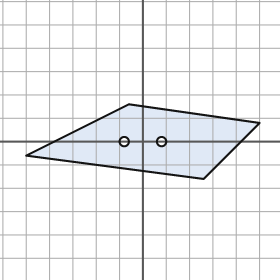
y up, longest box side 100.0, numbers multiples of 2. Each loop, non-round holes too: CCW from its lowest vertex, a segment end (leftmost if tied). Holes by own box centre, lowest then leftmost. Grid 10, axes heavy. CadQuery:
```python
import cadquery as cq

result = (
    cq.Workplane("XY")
    .moveTo(26.0, -16.0)
    .lineTo(50.0, 8.0)
    .lineTo(-6.0, 16.0)
    .lineTo(-50.0, -6.0)
    .close()
    .moveTo(-8.0, 0.0)
    .circle(2.0)
    .moveTo(8.0, 0.0)
    .circle(2.0)
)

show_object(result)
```